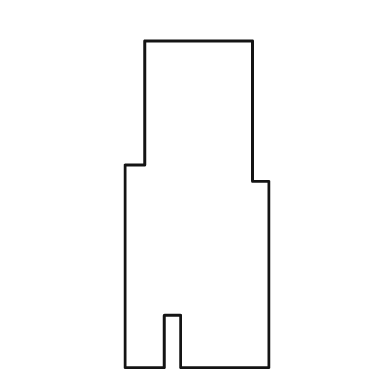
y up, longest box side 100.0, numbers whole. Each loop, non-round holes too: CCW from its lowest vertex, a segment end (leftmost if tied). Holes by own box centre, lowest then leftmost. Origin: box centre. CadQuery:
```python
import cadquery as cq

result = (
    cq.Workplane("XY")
    .moveTo(-22.0, -50.0)
    .lineTo(-10.0, -50.0)
    .lineTo(-10.0, -34.0)
    .lineTo(-5.0, -34.0)
    .lineTo(-5.0, -50.0)
    .lineTo(22.0, -50.0)
    .lineTo(22.0, 7.0)
    .lineTo(17.0, 7.0)
    .lineTo(17.0, 50.0)
    .lineTo(-16.0, 50.0)
    .lineTo(-16.0, 12.0)
    .lineTo(-22.0, 12.0)
    .close()
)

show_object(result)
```